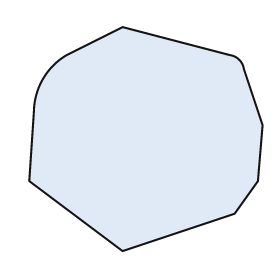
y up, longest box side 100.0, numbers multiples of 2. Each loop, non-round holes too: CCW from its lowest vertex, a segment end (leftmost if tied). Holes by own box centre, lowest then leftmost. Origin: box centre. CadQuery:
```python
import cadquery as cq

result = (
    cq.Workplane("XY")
    .moveTo(-10.0, -48.0)
    .lineTo(38.0, -32.0)
    .lineTo(48.0, -18.0)
    .lineTo(50.0, 6.0)
    .lineTo(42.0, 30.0)
    .threePointArc((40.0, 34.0), (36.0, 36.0))
    .lineTo(-10.0, 48.0)
    .lineTo(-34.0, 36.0)
    .threePointArc((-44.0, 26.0), (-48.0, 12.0))
    .lineTo(-50.0, -18.0)
    .close()
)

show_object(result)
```